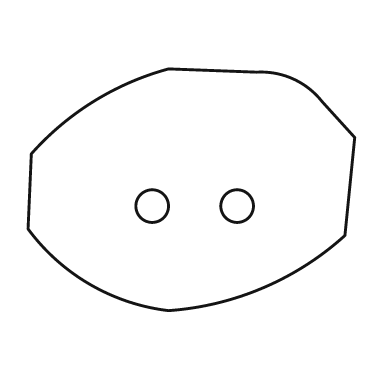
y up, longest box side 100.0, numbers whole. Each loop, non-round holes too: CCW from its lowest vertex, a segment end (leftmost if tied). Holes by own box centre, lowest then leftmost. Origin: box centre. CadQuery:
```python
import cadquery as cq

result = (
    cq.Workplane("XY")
    .moveTo(-7.0, -37.0)
    .threePointArc((22.0, -30.0), (47.0, -14.0))
    .lineTo(50.0, 16.0)
    .lineTo(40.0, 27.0)
    .threePointArc((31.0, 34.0), (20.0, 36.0))
    .lineTo(-7.0, 37.0)
    .threePointArc((-30.0, 27.0), (-49.0, 11.0))
    .lineTo(-50.0, -12.0)
    .threePointArc((-31.0, -29.0), (-7.0, -37.0))
    .close()
    .moveTo(-12.0, -5.0)
    .circle(5.0)
    .moveTo(14.0, -5.0)
    .circle(5.0)
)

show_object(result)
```